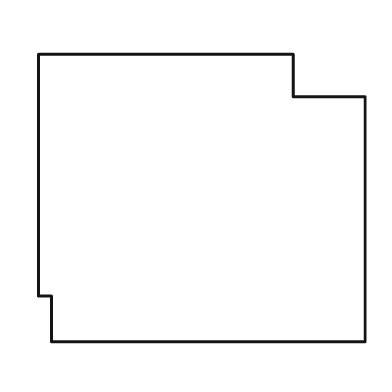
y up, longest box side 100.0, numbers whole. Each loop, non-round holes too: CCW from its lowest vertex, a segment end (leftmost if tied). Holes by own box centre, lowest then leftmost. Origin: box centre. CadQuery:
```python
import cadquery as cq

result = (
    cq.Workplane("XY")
    .moveTo(-46.0, -44.0)
    .lineTo(50.0, -44.0)
    .lineTo(50.0, 31.0)
    .lineTo(28.0, 31.0)
    .lineTo(28.0, 44.0)
    .lineTo(-50.0, 44.0)
    .lineTo(-50.0, -30.0)
    .lineTo(-46.0, -30.0)
    .close()
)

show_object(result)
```